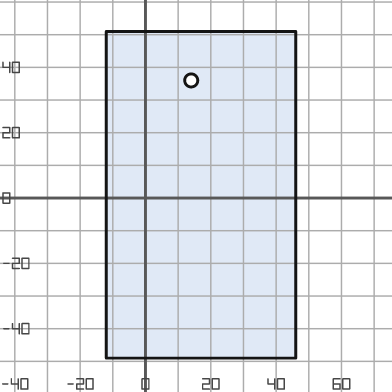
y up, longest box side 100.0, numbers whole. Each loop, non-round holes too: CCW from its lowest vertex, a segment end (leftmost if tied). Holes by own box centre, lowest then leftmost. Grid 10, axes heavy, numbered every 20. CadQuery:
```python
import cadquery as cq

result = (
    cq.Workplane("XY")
    .moveTo(-12.0, -49.0)
    .lineTo(46.0, -49.0)
    .lineTo(46.0, 51.0)
    .lineTo(-12.0, 51.0)
    .close()
    .moveTo(14.0, 36.0)
    .circle(2.0)
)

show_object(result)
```